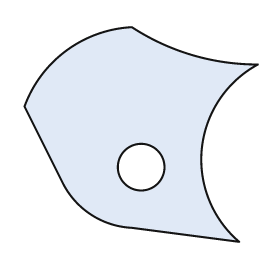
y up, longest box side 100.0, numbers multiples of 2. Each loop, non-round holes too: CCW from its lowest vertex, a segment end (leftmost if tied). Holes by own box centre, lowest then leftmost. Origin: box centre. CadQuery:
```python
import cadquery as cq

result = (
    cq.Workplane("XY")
    .moveTo(42.0, -46.0)
    .threePointArc((26.0, -6.0), (50.0, 30.0))
    .threePointArc((22.0, 34.0), (-4.0, 46.0))
    .threePointArc((-32.0, 36.0), (-50.0, 12.0))
    .lineTo(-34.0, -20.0)
    .threePointArc((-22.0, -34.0), (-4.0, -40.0))
    .close()
    .moveTo(0.0, -14.0)
    .circle(10.0)
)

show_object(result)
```